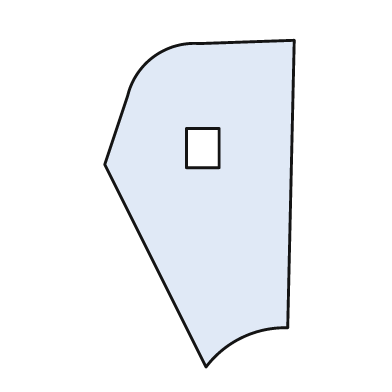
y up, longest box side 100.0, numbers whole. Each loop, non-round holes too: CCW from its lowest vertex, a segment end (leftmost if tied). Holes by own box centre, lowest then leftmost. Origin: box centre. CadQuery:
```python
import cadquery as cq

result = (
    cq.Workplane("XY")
    .moveTo(2.0, -50.0)
    .threePointArc((13.0, -41.0), (27.0, -38.0))
    .lineTo(29.0, 50.0)
    .lineTo(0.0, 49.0)
    .threePointArc((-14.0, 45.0), (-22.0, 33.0))
    .lineTo(-29.0, 12.0)
    .close()
    .moveTo(-4.0, 11.0)
    .lineTo(6.0, 11.0)
    .lineTo(6.0, 23.0)
    .lineTo(-4.0, 23.0)
    .close()
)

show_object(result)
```